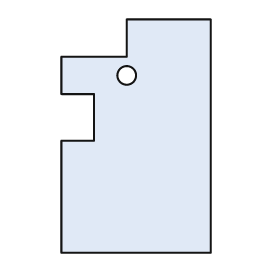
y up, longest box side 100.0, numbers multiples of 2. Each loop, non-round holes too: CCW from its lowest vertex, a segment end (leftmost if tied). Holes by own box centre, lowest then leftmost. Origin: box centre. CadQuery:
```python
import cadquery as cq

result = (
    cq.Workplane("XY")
    .moveTo(-32.0, -50.0)
    .lineTo(32.0, -50.0)
    .lineTo(32.0, 50.0)
    .lineTo(-4.0, 50.0)
    .lineTo(-4.0, 34.0)
    .lineTo(-32.0, 34.0)
    .lineTo(-32.0, 18.0)
    .lineTo(-18.0, 18.0)
    .lineTo(-18.0, -2.0)
    .lineTo(-32.0, -2.0)
    .close()
    .moveTo(-4.0, 26.0)
    .circle(4.0)
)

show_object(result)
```